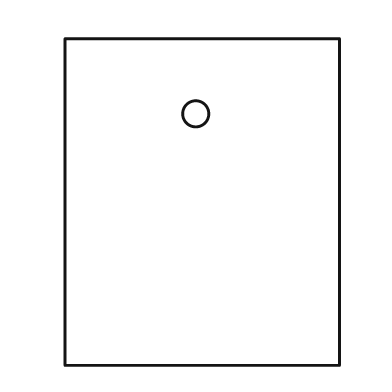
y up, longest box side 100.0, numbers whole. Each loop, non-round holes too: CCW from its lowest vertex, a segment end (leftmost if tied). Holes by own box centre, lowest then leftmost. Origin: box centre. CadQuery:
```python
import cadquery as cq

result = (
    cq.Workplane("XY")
    .moveTo(-42.0, -50.0)
    .lineTo(42.0, -50.0)
    .lineTo(42.0, 50.0)
    .lineTo(-42.0, 50.0)
    .close()
    .moveTo(-2.0, 27.0)
    .circle(4.0)
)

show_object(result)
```